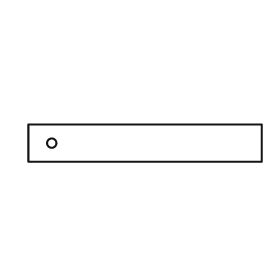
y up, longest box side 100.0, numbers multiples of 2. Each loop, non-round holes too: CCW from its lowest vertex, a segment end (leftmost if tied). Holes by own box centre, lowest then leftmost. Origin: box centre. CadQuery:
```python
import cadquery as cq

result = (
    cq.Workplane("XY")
    .moveTo(-50.0, -8.0)
    .lineTo(50.0, -8.0)
    .lineTo(50.0, 8.0)
    .lineTo(-50.0, 8.0)
    .close()
    .moveTo(-40.0, 0.0)
    .circle(2.0)
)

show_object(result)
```